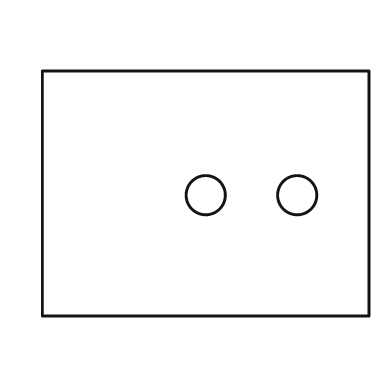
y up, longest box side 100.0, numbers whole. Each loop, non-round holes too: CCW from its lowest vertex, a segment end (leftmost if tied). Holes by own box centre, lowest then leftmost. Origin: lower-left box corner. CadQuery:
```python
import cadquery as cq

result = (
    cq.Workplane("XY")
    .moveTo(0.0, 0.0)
    .lineTo(100.0, 0.0)
    .lineTo(100.0, 75.0)
    .lineTo(0.0, 75.0)
    .close()
    .moveTo(50.0, 37.0)
    .circle(6.0)
    .moveTo(78.0, 37.0)
    .circle(6.0)
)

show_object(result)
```